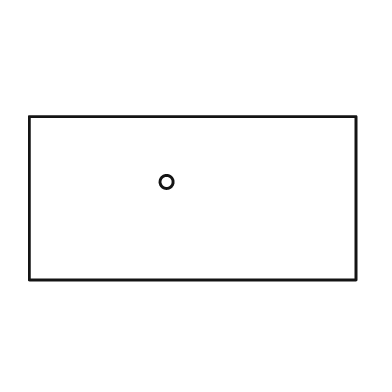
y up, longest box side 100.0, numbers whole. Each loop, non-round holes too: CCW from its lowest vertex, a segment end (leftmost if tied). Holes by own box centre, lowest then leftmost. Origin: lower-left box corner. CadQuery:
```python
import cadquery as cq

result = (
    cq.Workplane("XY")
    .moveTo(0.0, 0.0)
    .lineTo(100.0, 0.0)
    .lineTo(100.0, 50.0)
    .lineTo(0.0, 50.0)
    .close()
    .moveTo(42.0, 30.0)
    .circle(2.0)
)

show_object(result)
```